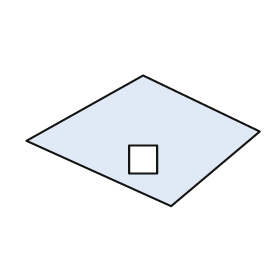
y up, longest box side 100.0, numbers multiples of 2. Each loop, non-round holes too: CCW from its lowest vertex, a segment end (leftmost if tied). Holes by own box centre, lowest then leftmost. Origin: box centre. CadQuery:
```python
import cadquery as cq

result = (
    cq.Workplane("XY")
    .moveTo(12.0, -28.0)
    .lineTo(50.0, 4.0)
    .lineTo(0.0, 28.0)
    .lineTo(-50.0, 0.0)
    .close()
    .moveTo(-6.0, -14.0)
    .lineTo(6.0, -14.0)
    .lineTo(6.0, -2.0)
    .lineTo(-6.0, -2.0)
    .close()
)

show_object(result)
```